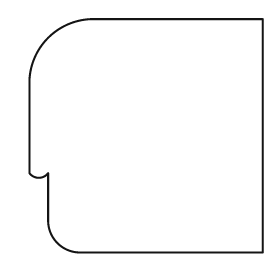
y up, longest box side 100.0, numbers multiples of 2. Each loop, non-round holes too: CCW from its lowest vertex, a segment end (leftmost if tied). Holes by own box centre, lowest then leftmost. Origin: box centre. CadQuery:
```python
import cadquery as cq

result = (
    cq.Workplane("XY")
    .moveTo(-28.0, -50.0)
    .lineTo(50.0, -50.0)
    .lineTo(50.0, 50.0)
    .lineTo(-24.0, 50.0)
    .threePointArc((-42.0, 42.0), (-50.0, 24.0))
    .lineTo(-50.0, -16.0)
    .threePointArc((-46.0, -18.0), (-42.0, -16.0))
    .lineTo(-42.0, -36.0)
    .threePointArc((-38.0, -46.0), (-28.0, -50.0))
    .close()
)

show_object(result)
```